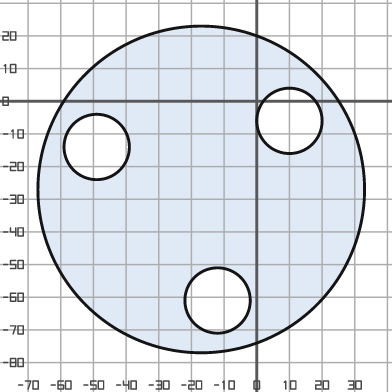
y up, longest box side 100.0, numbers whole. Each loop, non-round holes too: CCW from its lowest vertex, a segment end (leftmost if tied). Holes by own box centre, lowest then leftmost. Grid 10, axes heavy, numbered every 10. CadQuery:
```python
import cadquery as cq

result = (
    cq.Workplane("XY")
    .moveTo(-17.0, -27.0)
    .circle(50.0)
    .moveTo(-12.0, -61.0)
    .circle(10.0)
    .moveTo(-49.0, -14.0)
    .circle(10.0)
    .moveTo(10.0, -6.0)
    .circle(10.0)
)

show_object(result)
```